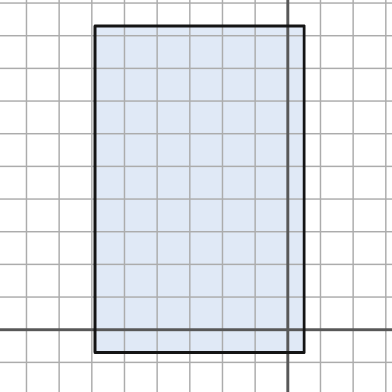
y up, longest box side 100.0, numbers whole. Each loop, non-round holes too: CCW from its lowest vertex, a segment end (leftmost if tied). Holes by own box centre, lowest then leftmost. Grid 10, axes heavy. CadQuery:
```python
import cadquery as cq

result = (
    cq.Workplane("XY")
    .moveTo(-59.0, -7.0)
    .lineTo(5.0, -7.0)
    .lineTo(5.0, 93.0)
    .lineTo(-59.0, 93.0)
    .close()
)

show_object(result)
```